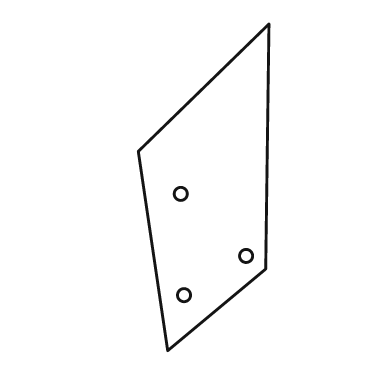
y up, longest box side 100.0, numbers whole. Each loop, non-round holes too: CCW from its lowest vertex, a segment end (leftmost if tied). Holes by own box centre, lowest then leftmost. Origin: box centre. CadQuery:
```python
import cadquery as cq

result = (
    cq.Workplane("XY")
    .moveTo(-11.0, -50.0)
    .lineTo(19.0, -25.0)
    .lineTo(20.0, 50.0)
    .lineTo(-20.0, 11.0)
    .close()
    .moveTo(-6.0, -33.0)
    .circle(2.0)
    .moveTo(13.0, -21.0)
    .circle(2.0)
    .moveTo(-7.0, -2.0)
    .circle(2.0)
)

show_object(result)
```